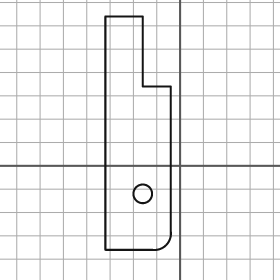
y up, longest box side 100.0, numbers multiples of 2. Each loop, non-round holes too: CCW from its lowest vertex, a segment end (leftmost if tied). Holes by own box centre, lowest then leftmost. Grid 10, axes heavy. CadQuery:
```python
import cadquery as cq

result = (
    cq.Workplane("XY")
    .moveTo(-32.0, -36.0)
    .lineTo(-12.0, -36.0)
    .threePointArc((-6.0, -34.0), (-4.0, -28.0))
    .lineTo(-4.0, 34.0)
    .lineTo(-16.0, 34.0)
    .lineTo(-16.0, 64.0)
    .lineTo(-32.0, 64.0)
    .close()
    .moveTo(-16.0, -12.0)
    .circle(4.0)
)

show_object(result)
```